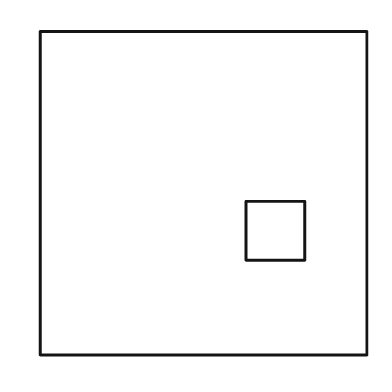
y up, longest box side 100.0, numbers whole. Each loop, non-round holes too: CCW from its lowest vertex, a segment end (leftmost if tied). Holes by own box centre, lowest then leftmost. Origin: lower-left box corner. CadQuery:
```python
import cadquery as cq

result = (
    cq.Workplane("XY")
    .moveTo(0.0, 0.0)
    .lineTo(100.0, 0.0)
    .lineTo(100.0, 99.0)
    .lineTo(0.0, 99.0)
    .close()
    .moveTo(63.0, 29.0)
    .lineTo(81.0, 29.0)
    .lineTo(81.0, 47.0)
    .lineTo(63.0, 47.0)
    .close()
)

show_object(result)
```